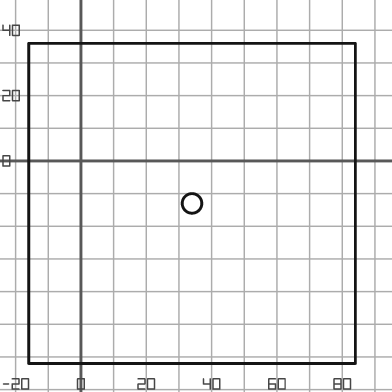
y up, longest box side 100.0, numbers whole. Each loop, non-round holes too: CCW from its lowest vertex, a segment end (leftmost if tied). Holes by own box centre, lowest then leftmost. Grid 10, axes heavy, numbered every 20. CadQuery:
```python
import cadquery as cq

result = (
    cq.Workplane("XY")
    .moveTo(-16.0, -62.0)
    .lineTo(84.0, -62.0)
    .lineTo(84.0, 36.0)
    .lineTo(-16.0, 36.0)
    .close()
    .moveTo(34.0, -13.0)
    .circle(3.0)
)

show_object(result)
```